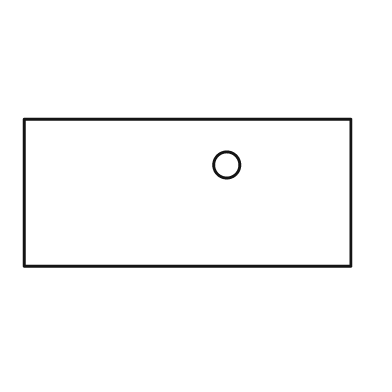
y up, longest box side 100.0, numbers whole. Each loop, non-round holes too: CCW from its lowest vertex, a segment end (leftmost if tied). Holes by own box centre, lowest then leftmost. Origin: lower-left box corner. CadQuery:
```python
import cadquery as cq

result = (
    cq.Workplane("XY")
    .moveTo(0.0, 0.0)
    .lineTo(100.0, 0.0)
    .lineTo(100.0, 45.0)
    .lineTo(0.0, 45.0)
    .close()
    .moveTo(62.0, 31.0)
    .circle(4.0)
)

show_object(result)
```